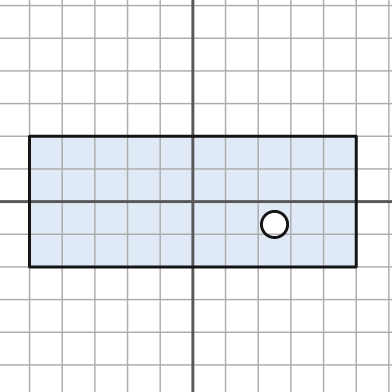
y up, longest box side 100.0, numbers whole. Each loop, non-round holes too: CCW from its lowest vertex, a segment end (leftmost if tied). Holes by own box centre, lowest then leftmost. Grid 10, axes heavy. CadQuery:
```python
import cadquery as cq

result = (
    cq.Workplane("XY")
    .moveTo(-50.0, -20.0)
    .lineTo(50.0, -20.0)
    .lineTo(50.0, 20.0)
    .lineTo(-50.0, 20.0)
    .close()
    .moveTo(25.0, -7.0)
    .circle(4.0)
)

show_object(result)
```